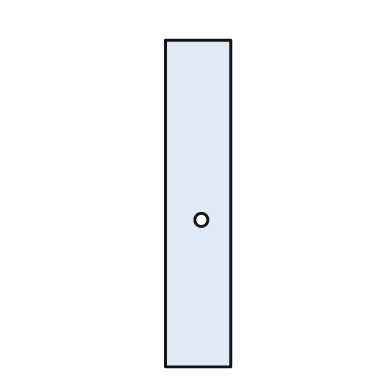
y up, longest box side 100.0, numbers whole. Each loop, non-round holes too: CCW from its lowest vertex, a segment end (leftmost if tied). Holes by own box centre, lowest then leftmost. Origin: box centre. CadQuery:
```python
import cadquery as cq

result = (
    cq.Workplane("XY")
    .moveTo(-10.0, -50.0)
    .lineTo(10.0, -50.0)
    .lineTo(10.0, 50.0)
    .lineTo(-10.0, 50.0)
    .close()
    .moveTo(1.0, -5.0)
    .circle(2.0)
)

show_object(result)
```